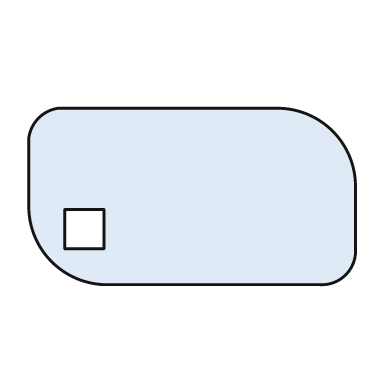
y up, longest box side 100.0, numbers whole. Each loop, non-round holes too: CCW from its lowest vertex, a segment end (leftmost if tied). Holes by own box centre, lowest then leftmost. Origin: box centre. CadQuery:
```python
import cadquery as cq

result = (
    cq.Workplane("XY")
    .moveTo(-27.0, -27.0)
    .lineTo(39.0, -27.0)
    .threePointArc((47.0, -24.0), (50.0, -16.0))
    .lineTo(50.0, 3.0)
    .threePointArc((43.0, 20.0), (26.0, 27.0))
    .lineTo(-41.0, 27.0)
    .threePointArc((-47.0, 24.0), (-50.0, 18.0))
    .lineTo(-50.0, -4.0)
    .threePointArc((-43.0, -20.0), (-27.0, -27.0))
    .close()
    .moveTo(-39.0, -16.0)
    .lineTo(-27.0, -16.0)
    .lineTo(-27.0, -4.0)
    .lineTo(-39.0, -4.0)
    .close()
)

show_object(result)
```